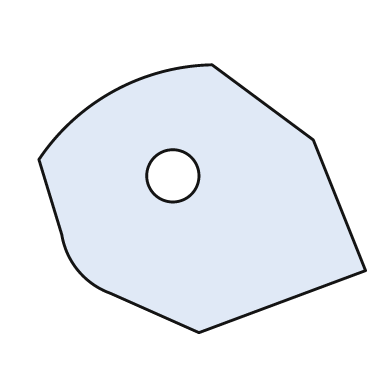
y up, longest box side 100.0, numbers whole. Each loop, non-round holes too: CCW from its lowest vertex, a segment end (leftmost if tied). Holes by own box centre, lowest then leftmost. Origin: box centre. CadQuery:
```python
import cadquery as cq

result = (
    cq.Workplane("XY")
    .moveTo(-1.0, -41.0)
    .lineTo(50.0, -22.0)
    .lineTo(34.0, 18.0)
    .lineTo(3.0, 41.0)
    .threePointArc((-27.0, 33.0), (-50.0, 12.0))
    .lineTo(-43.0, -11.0)
    .threePointArc((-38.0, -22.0), (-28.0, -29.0))
    .close()
    .moveTo(-9.0, 7.0)
    .circle(8.0)
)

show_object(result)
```